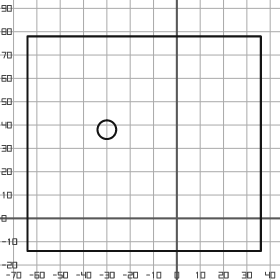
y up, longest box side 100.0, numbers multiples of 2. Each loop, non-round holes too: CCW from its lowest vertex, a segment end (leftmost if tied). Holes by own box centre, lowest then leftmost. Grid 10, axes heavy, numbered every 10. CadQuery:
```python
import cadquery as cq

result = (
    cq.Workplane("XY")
    .moveTo(-64.0, -14.0)
    .lineTo(36.0, -14.0)
    .lineTo(36.0, 78.0)
    .lineTo(-64.0, 78.0)
    .close()
    .moveTo(-30.0, 38.0)
    .circle(4.0)
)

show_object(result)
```